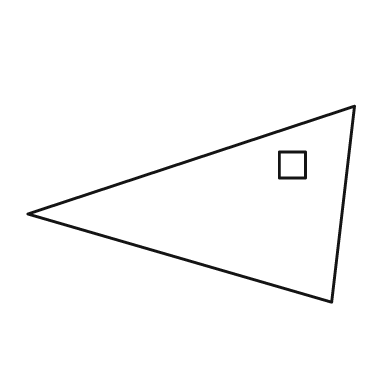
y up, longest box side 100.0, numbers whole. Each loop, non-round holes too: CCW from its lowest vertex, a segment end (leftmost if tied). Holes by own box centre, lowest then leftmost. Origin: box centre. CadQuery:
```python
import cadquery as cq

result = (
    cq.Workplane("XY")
    .moveTo(43.0, -30.0)
    .lineTo(50.0, 30.0)
    .lineTo(-50.0, -3.0)
    .close()
    .moveTo(27.0, 8.0)
    .lineTo(35.0, 8.0)
    .lineTo(35.0, 16.0)
    .lineTo(27.0, 16.0)
    .close()
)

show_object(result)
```